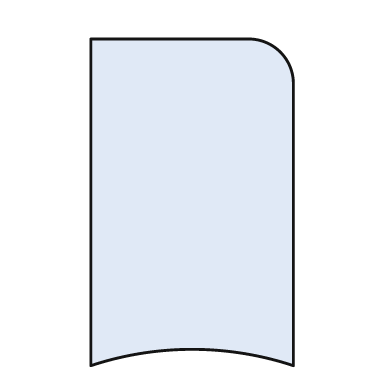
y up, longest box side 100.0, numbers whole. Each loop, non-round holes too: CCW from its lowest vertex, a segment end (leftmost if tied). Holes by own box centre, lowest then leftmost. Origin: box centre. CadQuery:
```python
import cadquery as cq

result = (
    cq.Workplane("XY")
    .moveTo(-31.0, -50.0)
    .threePointArc((0.0, -45.0), (31.0, -50.0))
    .lineTo(31.0, 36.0)
    .threePointArc((27.0, 46.0), (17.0, 50.0))
    .lineTo(-31.0, 50.0)
    .close()
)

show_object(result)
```